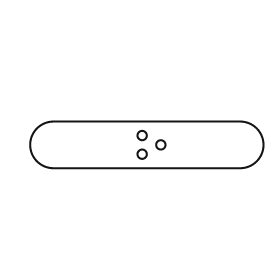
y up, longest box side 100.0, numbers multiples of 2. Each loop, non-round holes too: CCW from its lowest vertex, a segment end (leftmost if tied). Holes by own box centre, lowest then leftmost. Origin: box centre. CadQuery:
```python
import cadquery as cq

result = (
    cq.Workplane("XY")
    .moveTo(-40.0, -10.0)
    .lineTo(40.0, -10.0)
    .threePointArc((50.0, 0.0), (40.0, 10.0))
    .lineTo(-40.0, 10.0)
    .threePointArc((-50.0, 0.0), (-40.0, -10.0))
    .close()
    .moveTo(-2.0, -4.0)
    .circle(2.0)
    .moveTo(6.0, 0.0)
    .circle(2.0)
    .moveTo(-2.0, 4.0)
    .circle(2.0)
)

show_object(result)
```